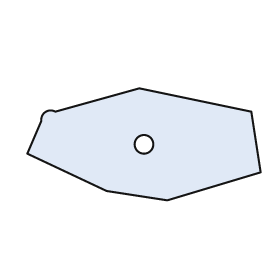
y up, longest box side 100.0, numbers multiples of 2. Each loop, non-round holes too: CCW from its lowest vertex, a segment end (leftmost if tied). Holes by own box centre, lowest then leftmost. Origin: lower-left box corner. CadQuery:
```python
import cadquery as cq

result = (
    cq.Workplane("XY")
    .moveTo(60.0, 0.0)
    .lineTo(100.0, 12.0)
    .lineTo(96.0, 38.0)
    .lineTo(48.0, 48.0)
    .lineTo(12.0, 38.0)
    .threePointArc((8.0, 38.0), (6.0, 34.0))
    .lineTo(0.0, 20.0)
    .lineTo(34.0, 4.0)
    .close()
    .moveTo(50.0, 24.0)
    .circle(4.0)
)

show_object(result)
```